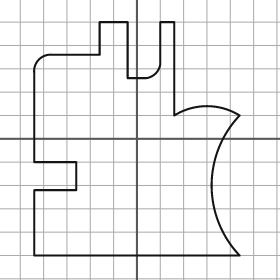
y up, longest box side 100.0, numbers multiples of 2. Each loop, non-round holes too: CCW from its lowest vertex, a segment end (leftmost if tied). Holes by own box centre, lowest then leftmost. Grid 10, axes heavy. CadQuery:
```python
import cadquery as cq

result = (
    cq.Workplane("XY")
    .moveTo(-44.0, -50.0)
    .lineTo(44.0, -50.0)
    .threePointArc((32.0, -20.0), (44.0, 10.0))
    .threePointArc((30.0, 14.0), (16.0, 10.0))
    .lineTo(16.0, 50.0)
    .lineTo(10.0, 50.0)
    .lineTo(10.0, 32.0)
    .threePointArc((8.0, 28.0), (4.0, 26.0))
    .lineTo(-4.0, 26.0)
    .lineTo(-4.0, 50.0)
    .lineTo(-16.0, 50.0)
    .lineTo(-16.0, 36.0)
    .lineTo(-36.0, 36.0)
    .threePointArc((-42.0, 34.0), (-44.0, 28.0))
    .lineTo(-44.0, -10.0)
    .lineTo(-26.0, -10.0)
    .lineTo(-26.0, -22.0)
    .lineTo(-44.0, -22.0)
    .close()
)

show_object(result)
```